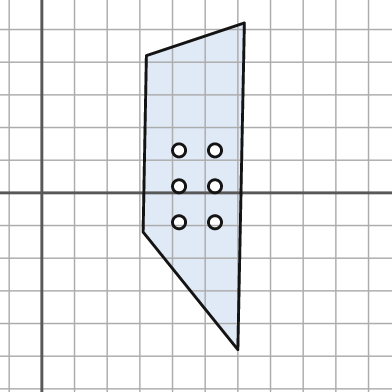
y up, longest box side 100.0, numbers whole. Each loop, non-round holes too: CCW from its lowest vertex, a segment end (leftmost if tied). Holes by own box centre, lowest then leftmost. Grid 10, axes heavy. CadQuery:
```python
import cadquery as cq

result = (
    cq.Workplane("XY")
    .moveTo(60.0, -48.0)
    .lineTo(62.0, 52.0)
    .lineTo(32.0, 42.0)
    .lineTo(31.0, -12.0)
    .close()
    .moveTo(42.0, -9.0)
    .circle(2.0)
    .moveTo(53.0, -9.0)
    .circle(2.0)
    .moveTo(42.0, 2.0)
    .circle(2.0)
    .moveTo(53.0, 2.0)
    .circle(2.0)
    .moveTo(42.0, 13.0)
    .circle(2.0)
    .moveTo(53.0, 13.0)
    .circle(2.0)
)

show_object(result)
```